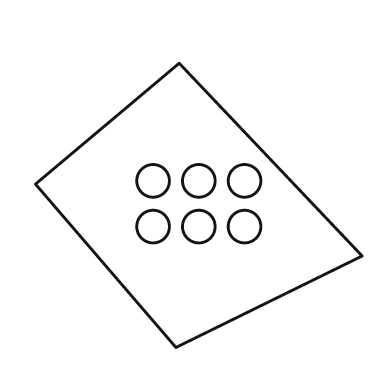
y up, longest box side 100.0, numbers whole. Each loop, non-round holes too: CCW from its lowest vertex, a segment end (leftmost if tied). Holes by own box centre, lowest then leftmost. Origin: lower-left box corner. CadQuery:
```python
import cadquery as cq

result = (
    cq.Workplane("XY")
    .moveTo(43.0, 0.0)
    .lineTo(100.0, 28.0)
    .lineTo(44.0, 87.0)
    .lineTo(0.0, 50.0)
    .close()
    .moveTo(36.0, 37.0)
    .circle(5.0)
    .moveTo(50.0, 37.0)
    .circle(5.0)
    .moveTo(64.0, 37.0)
    .circle(5.0)
    .moveTo(36.0, 51.0)
    .circle(5.0)
    .moveTo(50.0, 51.0)
    .circle(5.0)
    .moveTo(64.0, 51.0)
    .circle(5.0)
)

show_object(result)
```